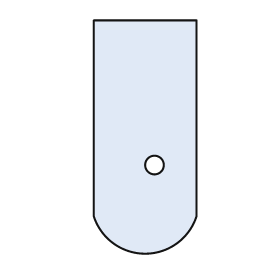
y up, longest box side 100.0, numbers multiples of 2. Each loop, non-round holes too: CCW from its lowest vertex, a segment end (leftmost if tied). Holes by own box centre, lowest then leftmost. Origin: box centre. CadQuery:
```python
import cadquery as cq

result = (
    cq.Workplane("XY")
    .moveTo(-22.0, -34.0)
    .threePointArc((0.0, -50.0), (22.0, -34.0))
    .lineTo(22.0, 50.0)
    .lineTo(-22.0, 50.0)
    .close()
    .moveTo(4.0, -12.0)
    .circle(4.0)
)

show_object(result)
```